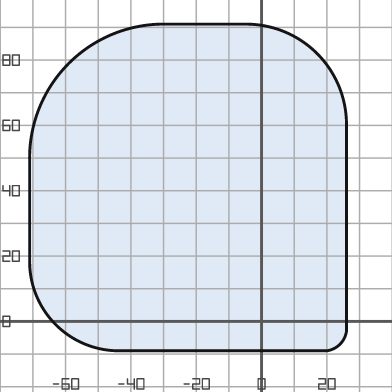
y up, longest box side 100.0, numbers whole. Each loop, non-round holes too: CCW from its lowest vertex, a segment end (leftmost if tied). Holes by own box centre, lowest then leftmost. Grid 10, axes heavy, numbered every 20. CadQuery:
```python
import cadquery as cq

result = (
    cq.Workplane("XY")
    .moveTo(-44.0, -9.0)
    .lineTo(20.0, -9.0)
    .threePointArc((24.0, -7.0), (26.0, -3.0))
    .lineTo(26.0, 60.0)
    .threePointArc((17.0, 82.0), (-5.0, 91.0))
    .lineTo(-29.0, 91.0)
    .threePointArc((-59.0, 79.0), (-71.0, 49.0))
    .lineTo(-71.0, 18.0)
    .threePointArc((-63.0, -1.0), (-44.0, -9.0))
    .close()
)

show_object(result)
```